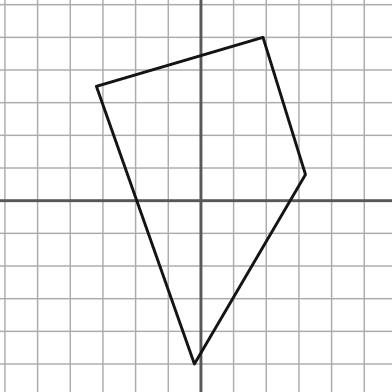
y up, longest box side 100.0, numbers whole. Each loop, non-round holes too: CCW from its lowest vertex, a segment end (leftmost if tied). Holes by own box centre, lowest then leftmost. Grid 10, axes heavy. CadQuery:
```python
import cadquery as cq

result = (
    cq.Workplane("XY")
    .moveTo(-2.0, -50.0)
    .lineTo(32.0, 8.0)
    .lineTo(19.0, 50.0)
    .lineTo(-32.0, 35.0)
    .close()
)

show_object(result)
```